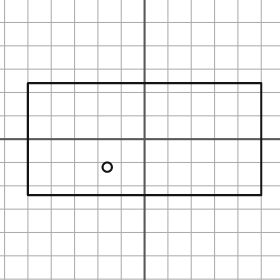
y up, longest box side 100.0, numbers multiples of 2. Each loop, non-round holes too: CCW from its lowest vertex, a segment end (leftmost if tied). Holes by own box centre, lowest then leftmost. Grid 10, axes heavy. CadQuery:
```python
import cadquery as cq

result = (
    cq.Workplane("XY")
    .moveTo(-50.0, -24.0)
    .lineTo(50.0, -24.0)
    .lineTo(50.0, 24.0)
    .lineTo(-50.0, 24.0)
    .close()
    .moveTo(-16.0, -12.0)
    .circle(2.0)
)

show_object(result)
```